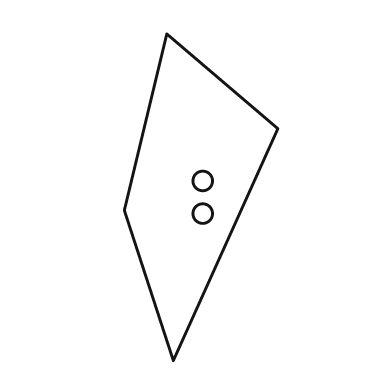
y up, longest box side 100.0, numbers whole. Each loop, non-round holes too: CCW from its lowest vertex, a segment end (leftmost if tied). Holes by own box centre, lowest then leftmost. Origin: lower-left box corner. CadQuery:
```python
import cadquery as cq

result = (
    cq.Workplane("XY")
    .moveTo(15.0, 0.0)
    .lineTo(47.0, 71.0)
    .lineTo(13.0, 100.0)
    .lineTo(0.0, 46.0)
    .close()
    .moveTo(24.0, 45.0)
    .circle(3.0)
    .moveTo(24.0, 55.0)
    .circle(3.0)
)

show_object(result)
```